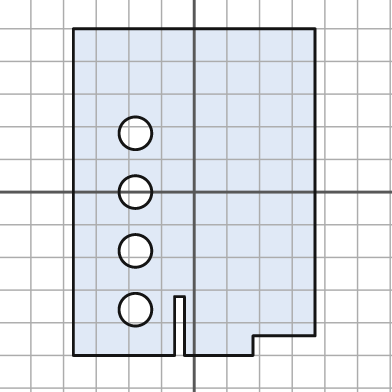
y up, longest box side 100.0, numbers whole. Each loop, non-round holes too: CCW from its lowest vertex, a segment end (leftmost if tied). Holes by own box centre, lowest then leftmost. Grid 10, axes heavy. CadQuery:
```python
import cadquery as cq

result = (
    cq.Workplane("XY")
    .moveTo(-37.0, -50.0)
    .lineTo(-6.0, -50.0)
    .lineTo(-6.0, -32.0)
    .lineTo(-3.0, -32.0)
    .lineTo(-3.0, -50.0)
    .lineTo(18.0, -50.0)
    .lineTo(18.0, -44.0)
    .lineTo(37.0, -44.0)
    .lineTo(37.0, 50.0)
    .lineTo(-37.0, 50.0)
    .close()
    .moveTo(-18.0, -36.0)
    .circle(5.0)
    .moveTo(-18.0, -18.0)
    .circle(5.0)
    .moveTo(-18.0, 0.0)
    .circle(5.0)
    .moveTo(-18.0, 18.0)
    .circle(5.0)
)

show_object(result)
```